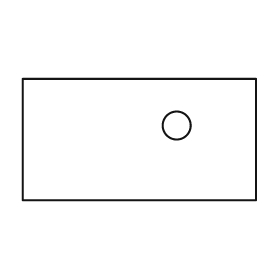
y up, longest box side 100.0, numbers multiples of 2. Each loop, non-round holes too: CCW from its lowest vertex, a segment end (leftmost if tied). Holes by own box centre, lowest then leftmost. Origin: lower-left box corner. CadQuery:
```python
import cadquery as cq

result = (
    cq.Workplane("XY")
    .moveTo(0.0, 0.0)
    .lineTo(100.0, 0.0)
    .lineTo(100.0, 52.0)
    .lineTo(0.0, 52.0)
    .close()
    .moveTo(66.0, 32.0)
    .circle(6.0)
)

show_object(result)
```